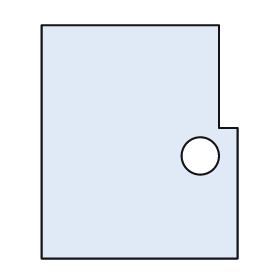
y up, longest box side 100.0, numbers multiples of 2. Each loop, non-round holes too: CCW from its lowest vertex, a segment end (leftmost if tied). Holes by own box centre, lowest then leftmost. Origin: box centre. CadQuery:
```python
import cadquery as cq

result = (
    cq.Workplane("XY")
    .moveTo(-42.0, -50.0)
    .lineTo(42.0, -50.0)
    .lineTo(42.0, 6.0)
    .lineTo(34.0, 6.0)
    .lineTo(34.0, 50.0)
    .lineTo(-42.0, 50.0)
    .close()
    .moveTo(26.0, -6.0)
    .circle(8.0)
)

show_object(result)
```